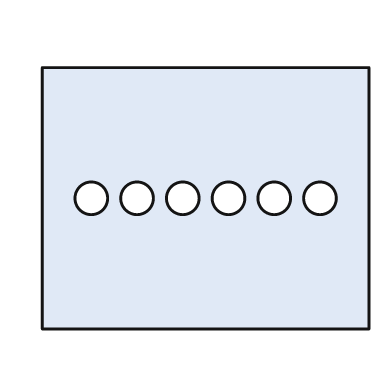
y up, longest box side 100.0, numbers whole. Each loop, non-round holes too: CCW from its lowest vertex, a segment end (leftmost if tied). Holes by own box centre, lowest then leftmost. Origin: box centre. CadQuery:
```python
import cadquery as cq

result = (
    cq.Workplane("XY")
    .moveTo(-50.0, -40.0)
    .lineTo(50.0, -40.0)
    .lineTo(50.0, 40.0)
    .lineTo(-50.0, 40.0)
    .close()
    .moveTo(-35.0, 0.0)
    .circle(5.0)
    .moveTo(-21.0, 0.0)
    .circle(5.0)
    .moveTo(-7.0, 0.0)
    .circle(5.0)
    .moveTo(7.0, 0.0)
    .circle(5.0)
    .moveTo(21.0, 0.0)
    .circle(5.0)
    .moveTo(35.0, 0.0)
    .circle(5.0)
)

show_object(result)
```